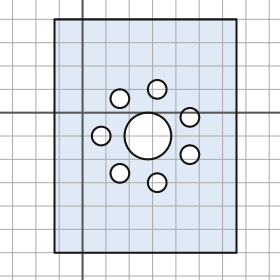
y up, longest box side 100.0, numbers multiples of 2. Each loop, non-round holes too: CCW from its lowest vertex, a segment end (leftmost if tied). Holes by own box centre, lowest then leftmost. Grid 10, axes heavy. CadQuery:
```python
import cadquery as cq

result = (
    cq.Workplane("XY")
    .moveTo(-12.0, -60.0)
    .lineTo(66.0, -60.0)
    .lineTo(66.0, 40.0)
    .lineTo(-12.0, 40.0)
    .close()
    .moveTo(32.0, -30.0)
    .circle(4.0)
    .moveTo(16.0, -26.0)
    .circle(4.0)
    .moveTo(46.0, -18.0)
    .circle(4.0)
    .moveTo(8.0, -10.0)
    .circle(4.0)
    .moveTo(28.0, -10.0)
    .circle(10.0)
    .moveTo(46.0, -2.0)
    .circle(4.0)
    .moveTo(16.0, 6.0)
    .circle(4.0)
    .moveTo(32.0, 10.0)
    .circle(4.0)
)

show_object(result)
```